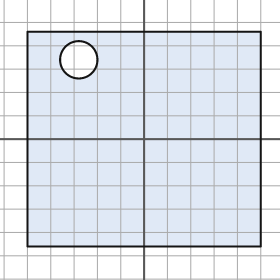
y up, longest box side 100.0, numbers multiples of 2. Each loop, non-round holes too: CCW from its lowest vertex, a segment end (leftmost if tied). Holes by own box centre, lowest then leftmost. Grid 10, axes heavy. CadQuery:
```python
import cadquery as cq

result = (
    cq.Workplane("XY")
    .moveTo(-50.0, -46.0)
    .lineTo(50.0, -46.0)
    .lineTo(50.0, 46.0)
    .lineTo(-50.0, 46.0)
    .close()
    .moveTo(-28.0, 34.0)
    .circle(8.0)
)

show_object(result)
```